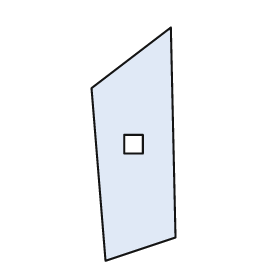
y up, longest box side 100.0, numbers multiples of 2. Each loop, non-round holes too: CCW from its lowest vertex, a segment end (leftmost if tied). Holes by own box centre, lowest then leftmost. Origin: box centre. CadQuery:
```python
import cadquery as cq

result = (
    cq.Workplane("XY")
    .moveTo(-12.0, -50.0)
    .lineTo(18.0, -40.0)
    .lineTo(16.0, 50.0)
    .lineTo(-18.0, 24.0)
    .close()
    .moveTo(-4.0, -4.0)
    .lineTo(4.0, -4.0)
    .lineTo(4.0, 4.0)
    .lineTo(-4.0, 4.0)
    .close()
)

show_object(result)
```